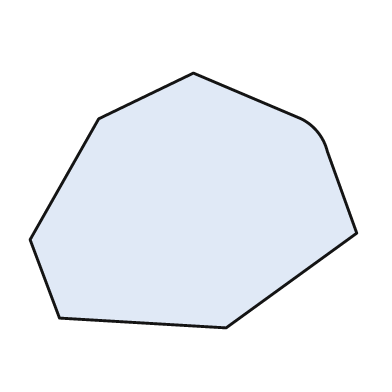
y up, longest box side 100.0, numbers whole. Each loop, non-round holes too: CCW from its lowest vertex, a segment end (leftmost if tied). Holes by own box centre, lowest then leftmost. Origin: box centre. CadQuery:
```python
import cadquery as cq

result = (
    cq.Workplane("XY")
    .moveTo(10.0, -39.0)
    .lineTo(50.0, -10.0)
    .lineTo(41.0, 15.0)
    .threePointArc((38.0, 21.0), (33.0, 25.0))
    .lineTo(0.0, 39.0)
    .lineTo(-29.0, 25.0)
    .lineTo(-50.0, -12.0)
    .lineTo(-41.0, -36.0)
    .close()
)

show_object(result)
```